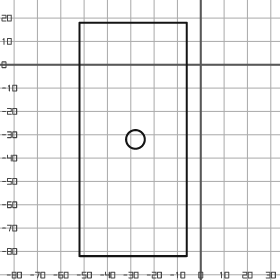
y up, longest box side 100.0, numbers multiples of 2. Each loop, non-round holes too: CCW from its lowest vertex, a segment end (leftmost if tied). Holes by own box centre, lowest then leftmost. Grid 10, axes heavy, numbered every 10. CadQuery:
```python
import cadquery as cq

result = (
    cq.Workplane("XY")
    .moveTo(-52.0, -82.0)
    .lineTo(-6.0, -82.0)
    .lineTo(-6.0, 18.0)
    .lineTo(-52.0, 18.0)
    .close()
    .moveTo(-28.0, -32.0)
    .circle(4.0)
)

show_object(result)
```